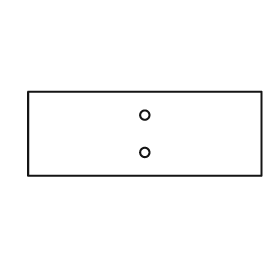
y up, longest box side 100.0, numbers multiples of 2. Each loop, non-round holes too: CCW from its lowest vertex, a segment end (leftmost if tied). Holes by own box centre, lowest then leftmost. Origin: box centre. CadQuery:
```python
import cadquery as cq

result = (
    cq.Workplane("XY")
    .moveTo(-50.0, -18.0)
    .lineTo(50.0, -18.0)
    .lineTo(50.0, 18.0)
    .lineTo(-50.0, 18.0)
    .close()
    .moveTo(0.0, -8.0)
    .circle(2.0)
    .moveTo(0.0, 8.0)
    .circle(2.0)
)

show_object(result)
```